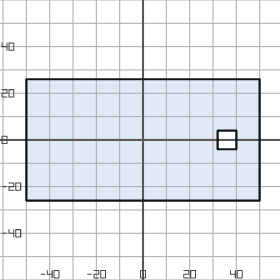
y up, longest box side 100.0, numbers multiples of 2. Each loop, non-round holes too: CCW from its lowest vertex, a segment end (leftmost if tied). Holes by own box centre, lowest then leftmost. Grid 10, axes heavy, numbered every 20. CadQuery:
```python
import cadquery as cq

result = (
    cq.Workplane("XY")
    .moveTo(-50.0, -26.0)
    .lineTo(50.0, -26.0)
    .lineTo(50.0, 26.0)
    .lineTo(-50.0, 26.0)
    .close()
    .moveTo(32.0, -4.0)
    .lineTo(40.0, -4.0)
    .lineTo(40.0, 4.0)
    .lineTo(32.0, 4.0)
    .close()
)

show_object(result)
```